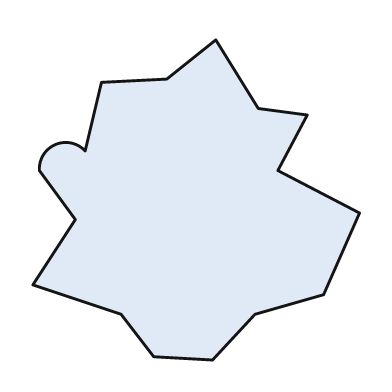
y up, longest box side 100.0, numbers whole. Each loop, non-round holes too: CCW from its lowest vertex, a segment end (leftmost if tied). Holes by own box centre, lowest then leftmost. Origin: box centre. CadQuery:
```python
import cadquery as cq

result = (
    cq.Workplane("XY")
    .moveTo(5.0, -49.0)
    .lineTo(18.0, -35.0)
    .lineTo(39.0, -29.0)
    .lineTo(50.0, -4.0)
    .lineTo(25.0, 9.0)
    .lineTo(34.0, 26.0)
    .lineTo(19.0, 28.0)
    .lineTo(6.0, 49.0)
    .lineTo(-9.0, 37.0)
    .lineTo(-29.0, 36.0)
    .lineTo(-34.0, 15.0)
    .threePointArc((-43.0, 17.0), (-48.0, 9.0))
    .lineTo(-37.0, -6.0)
    .lineTo(-50.0, -26.0)
    .lineTo(-23.0, -35.0)
    .lineTo(-13.0, -48.0)
    .close()
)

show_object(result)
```